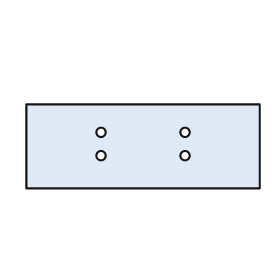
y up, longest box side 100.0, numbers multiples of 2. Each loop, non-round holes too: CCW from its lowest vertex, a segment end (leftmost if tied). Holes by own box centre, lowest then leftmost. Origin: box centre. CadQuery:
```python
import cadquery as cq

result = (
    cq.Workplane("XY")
    .moveTo(-50.0, -18.0)
    .lineTo(50.0, -18.0)
    .lineTo(50.0, 18.0)
    .lineTo(-50.0, 18.0)
    .close()
    .moveTo(-18.0, -4.0)
    .circle(2.0)
    .moveTo(18.0, -4.0)
    .circle(2.0)
    .moveTo(-18.0, 6.0)
    .circle(2.0)
    .moveTo(18.0, 6.0)
    .circle(2.0)
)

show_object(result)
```